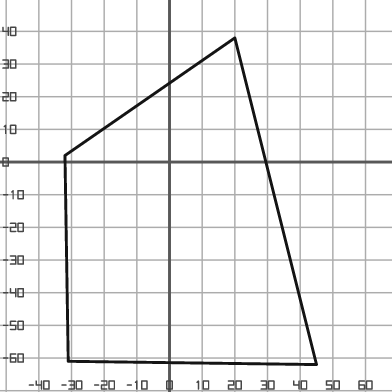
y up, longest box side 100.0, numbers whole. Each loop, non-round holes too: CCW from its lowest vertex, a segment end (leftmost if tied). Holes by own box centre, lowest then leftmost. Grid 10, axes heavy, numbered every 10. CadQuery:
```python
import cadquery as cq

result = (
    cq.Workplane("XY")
    .moveTo(45.0, -62.0)
    .lineTo(20.0, 38.0)
    .lineTo(-32.0, 2.0)
    .lineTo(-31.0, -61.0)
    .close()
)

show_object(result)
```